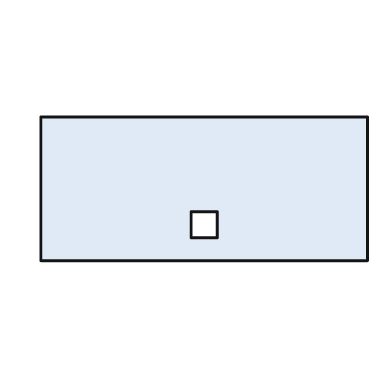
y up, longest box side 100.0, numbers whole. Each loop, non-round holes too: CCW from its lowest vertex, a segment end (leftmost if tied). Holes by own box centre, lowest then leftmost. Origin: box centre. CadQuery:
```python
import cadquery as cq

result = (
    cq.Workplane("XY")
    .moveTo(-50.0, -22.0)
    .lineTo(50.0, -22.0)
    .lineTo(50.0, 22.0)
    .lineTo(-50.0, 22.0)
    .close()
    .moveTo(-4.0, -15.0)
    .lineTo(4.0, -15.0)
    .lineTo(4.0, -7.0)
    .lineTo(-4.0, -7.0)
    .close()
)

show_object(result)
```